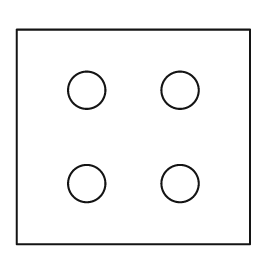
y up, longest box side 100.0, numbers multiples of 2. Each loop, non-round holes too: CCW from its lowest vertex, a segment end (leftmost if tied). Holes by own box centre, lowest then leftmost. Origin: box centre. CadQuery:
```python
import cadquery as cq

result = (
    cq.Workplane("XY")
    .moveTo(-50.0, -46.0)
    .lineTo(50.0, -46.0)
    .lineTo(50.0, 46.0)
    .lineTo(-50.0, 46.0)
    .close()
    .moveTo(-20.0, -20.0)
    .circle(8.0)
    .moveTo(20.0, -20.0)
    .circle(8.0)
    .moveTo(-20.0, 20.0)
    .circle(8.0)
    .moveTo(20.0, 20.0)
    .circle(8.0)
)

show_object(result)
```